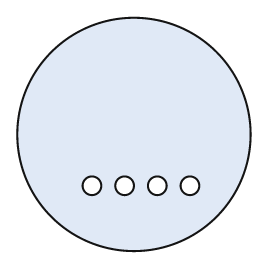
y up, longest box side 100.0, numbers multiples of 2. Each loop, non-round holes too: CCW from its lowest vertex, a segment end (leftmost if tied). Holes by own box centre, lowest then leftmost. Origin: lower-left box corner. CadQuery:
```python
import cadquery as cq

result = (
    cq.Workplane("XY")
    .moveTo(50.0, 50.0)
    .circle(50.0)
    .moveTo(32.0, 28.0)
    .circle(4.0)
    .moveTo(46.0, 28.0)
    .circle(4.0)
    .moveTo(60.0, 28.0)
    .circle(4.0)
    .moveTo(74.0, 28.0)
    .circle(4.0)
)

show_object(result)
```